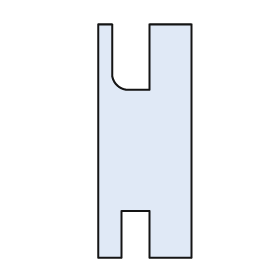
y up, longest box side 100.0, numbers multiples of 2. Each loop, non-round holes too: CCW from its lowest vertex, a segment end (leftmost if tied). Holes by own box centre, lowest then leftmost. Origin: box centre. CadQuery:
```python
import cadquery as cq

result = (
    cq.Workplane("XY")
    .moveTo(-20.0, -50.0)
    .lineTo(-10.0, -50.0)
    .lineTo(-10.0, -30.0)
    .lineTo(2.0, -30.0)
    .lineTo(2.0, -50.0)
    .lineTo(20.0, -50.0)
    .lineTo(20.0, 50.0)
    .lineTo(2.0, 50.0)
    .lineTo(2.0, 22.0)
    .lineTo(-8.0, 22.0)
    .threePointArc((-12.0, 24.0), (-14.0, 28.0))
    .lineTo(-14.0, 50.0)
    .lineTo(-20.0, 50.0)
    .close()
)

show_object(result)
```